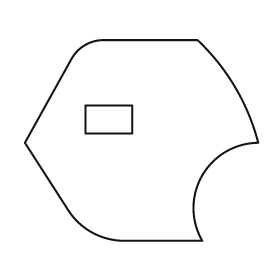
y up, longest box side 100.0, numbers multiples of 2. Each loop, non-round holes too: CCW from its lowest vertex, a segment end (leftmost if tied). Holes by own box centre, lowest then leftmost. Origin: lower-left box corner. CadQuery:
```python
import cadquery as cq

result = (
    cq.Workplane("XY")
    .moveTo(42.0, 0.0)
    .lineTo(76.0, 0.0)
    .threePointArc((76.0, 28.0), (100.0, 42.0))
    .threePointArc((90.0, 66.0), (74.0, 86.0))
    .lineTo(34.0, 86.0)
    .threePointArc((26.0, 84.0), (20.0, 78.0))
    .lineTo(0.0, 42.0)
    .lineTo(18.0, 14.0)
    .threePointArc((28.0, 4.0), (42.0, 0.0))
    .close()
    .moveTo(26.0, 46.0)
    .lineTo(46.0, 46.0)
    .lineTo(46.0, 58.0)
    .lineTo(26.0, 58.0)
    .close()
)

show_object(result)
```